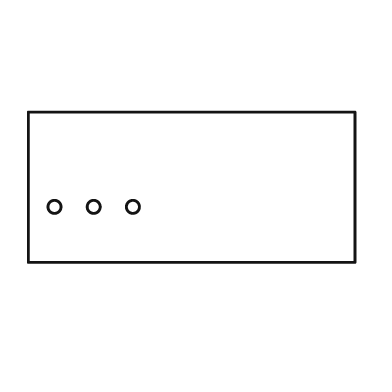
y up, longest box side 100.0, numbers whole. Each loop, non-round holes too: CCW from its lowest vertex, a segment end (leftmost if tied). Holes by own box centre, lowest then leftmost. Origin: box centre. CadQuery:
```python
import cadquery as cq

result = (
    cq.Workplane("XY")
    .moveTo(-50.0, -23.0)
    .lineTo(50.0, -23.0)
    .lineTo(50.0, 23.0)
    .lineTo(-50.0, 23.0)
    .close()
    .moveTo(-42.0, -6.0)
    .circle(2.0)
    .moveTo(-30.0, -6.0)
    .circle(2.0)
    .moveTo(-18.0, -6.0)
    .circle(2.0)
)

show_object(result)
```